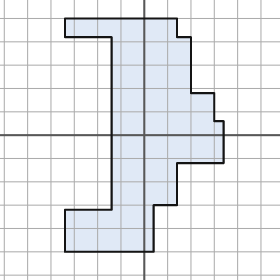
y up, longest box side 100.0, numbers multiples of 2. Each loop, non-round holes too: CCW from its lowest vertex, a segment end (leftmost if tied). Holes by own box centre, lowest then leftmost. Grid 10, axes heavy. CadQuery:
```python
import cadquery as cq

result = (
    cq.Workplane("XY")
    .moveTo(-34.0, -50.0)
    .lineTo(4.0, -50.0)
    .lineTo(4.0, -30.0)
    .lineTo(14.0, -30.0)
    .lineTo(14.0, -12.0)
    .lineTo(34.0, -12.0)
    .lineTo(34.0, 6.0)
    .lineTo(30.0, 6.0)
    .lineTo(30.0, 18.0)
    .lineTo(20.0, 18.0)
    .lineTo(20.0, 42.0)
    .lineTo(14.0, 42.0)
    .lineTo(14.0, 50.0)
    .lineTo(-34.0, 50.0)
    .lineTo(-34.0, 42.0)
    .lineTo(-14.0, 42.0)
    .lineTo(-14.0, -32.0)
    .lineTo(-34.0, -32.0)
    .close()
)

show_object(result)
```